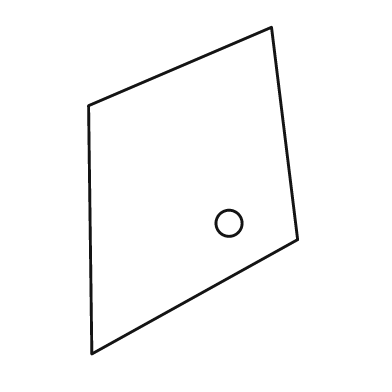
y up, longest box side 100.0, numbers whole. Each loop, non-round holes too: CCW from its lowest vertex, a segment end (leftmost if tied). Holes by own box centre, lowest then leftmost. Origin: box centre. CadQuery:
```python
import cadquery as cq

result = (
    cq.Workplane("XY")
    .moveTo(-31.0, -50.0)
    .lineTo(32.0, -15.0)
    .lineTo(24.0, 50.0)
    .lineTo(-32.0, 26.0)
    .close()
    .moveTo(11.0, -10.0)
    .circle(4.0)
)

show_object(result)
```